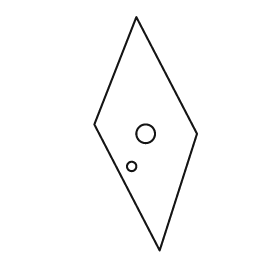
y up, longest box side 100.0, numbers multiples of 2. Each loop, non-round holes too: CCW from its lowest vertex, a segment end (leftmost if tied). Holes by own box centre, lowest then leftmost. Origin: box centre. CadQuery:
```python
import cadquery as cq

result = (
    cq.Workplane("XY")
    .moveTo(6.0, -50.0)
    .lineTo(22.0, 0.0)
    .lineTo(-4.0, 50.0)
    .lineTo(-22.0, 4.0)
    .close()
    .moveTo(-6.0, -14.0)
    .circle(2.0)
    .moveTo(0.0, 0.0)
    .circle(4.0)
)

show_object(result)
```